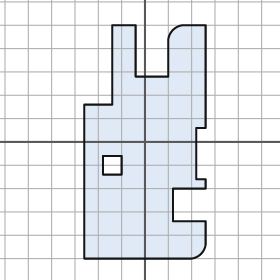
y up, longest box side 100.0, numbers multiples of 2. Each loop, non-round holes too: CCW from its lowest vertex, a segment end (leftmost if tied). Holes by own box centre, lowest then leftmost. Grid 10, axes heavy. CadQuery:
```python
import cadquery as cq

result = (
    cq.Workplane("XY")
    .moveTo(-26.0, -50.0)
    .lineTo(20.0, -50.0)
    .threePointArc((24.0, -48.0), (26.0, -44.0))
    .lineTo(26.0, -34.0)
    .lineTo(12.0, -34.0)
    .lineTo(12.0, -20.0)
    .lineTo(26.0, -20.0)
    .lineTo(26.0, -16.0)
    .lineTo(22.0, -16.0)
    .lineTo(22.0, 6.0)
    .lineTo(26.0, 6.0)
    .lineTo(26.0, 50.0)
    .lineTo(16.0, 50.0)
    .threePointArc((12.0, 48.0), (10.0, 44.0))
    .lineTo(10.0, 28.0)
    .lineTo(-4.0, 28.0)
    .lineTo(-4.0, 50.0)
    .lineTo(-14.0, 50.0)
    .lineTo(-14.0, 16.0)
    .lineTo(-26.0, 16.0)
    .close()
    .moveTo(-18.0, -14.0)
    .lineTo(-10.0, -14.0)
    .lineTo(-10.0, -6.0)
    .lineTo(-18.0, -6.0)
    .close()
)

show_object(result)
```